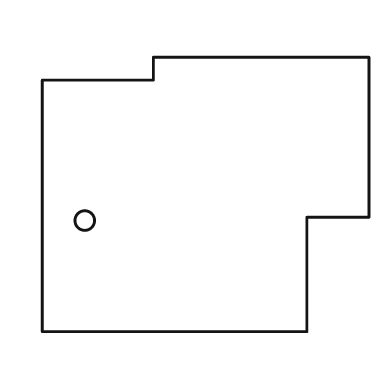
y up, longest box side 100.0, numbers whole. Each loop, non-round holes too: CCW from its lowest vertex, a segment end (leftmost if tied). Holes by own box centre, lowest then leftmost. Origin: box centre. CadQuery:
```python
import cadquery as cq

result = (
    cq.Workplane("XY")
    .moveTo(-50.0, -42.0)
    .lineTo(31.0, -42.0)
    .lineTo(31.0, -7.0)
    .lineTo(50.0, -7.0)
    .lineTo(50.0, 42.0)
    .lineTo(-16.0, 42.0)
    .lineTo(-16.0, 35.0)
    .lineTo(-50.0, 35.0)
    .close()
    .moveTo(-37.0, -8.0)
    .circle(3.0)
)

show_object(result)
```